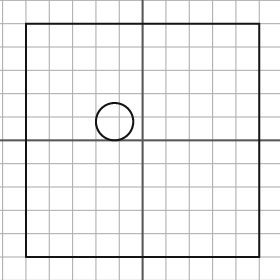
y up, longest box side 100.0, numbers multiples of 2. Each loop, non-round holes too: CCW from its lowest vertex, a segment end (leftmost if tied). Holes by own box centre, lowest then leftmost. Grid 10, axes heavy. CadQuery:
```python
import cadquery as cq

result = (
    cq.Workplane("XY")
    .moveTo(-50.0, -50.0)
    .lineTo(50.0, -50.0)
    .lineTo(50.0, 50.0)
    .lineTo(-50.0, 50.0)
    .close()
    .moveTo(-12.0, 8.0)
    .circle(8.0)
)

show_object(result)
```